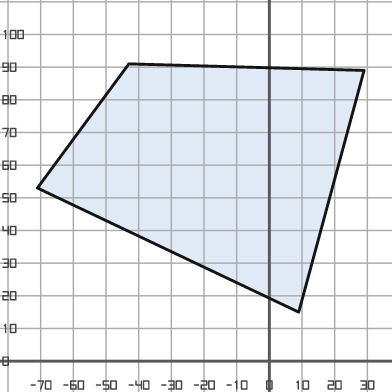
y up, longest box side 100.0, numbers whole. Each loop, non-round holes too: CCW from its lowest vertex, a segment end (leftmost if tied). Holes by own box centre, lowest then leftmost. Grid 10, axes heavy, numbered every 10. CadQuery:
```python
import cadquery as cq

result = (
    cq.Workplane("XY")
    .moveTo(9.0, 15.0)
    .lineTo(29.0, 89.0)
    .lineTo(-43.0, 91.0)
    .lineTo(-71.0, 53.0)
    .close()
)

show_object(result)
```